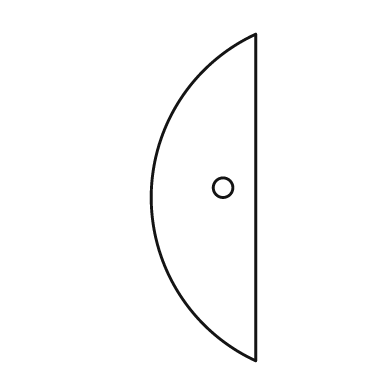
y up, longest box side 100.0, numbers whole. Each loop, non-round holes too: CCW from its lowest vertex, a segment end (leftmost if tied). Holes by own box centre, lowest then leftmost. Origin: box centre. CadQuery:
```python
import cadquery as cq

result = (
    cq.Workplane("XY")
    .moveTo(16.0, -50.0)
    .lineTo(16.0, 50.0)
    .threePointArc((-16.0, 0.0), (16.0, -50.0))
    .close()
    .moveTo(6.0, 3.0)
    .circle(3.0)
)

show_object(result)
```